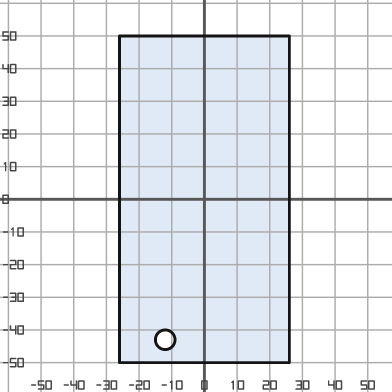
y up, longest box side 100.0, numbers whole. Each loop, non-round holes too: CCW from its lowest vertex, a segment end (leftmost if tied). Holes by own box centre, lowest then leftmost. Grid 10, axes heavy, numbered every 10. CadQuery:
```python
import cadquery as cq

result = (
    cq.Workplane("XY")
    .moveTo(-26.0, -50.0)
    .lineTo(26.0, -50.0)
    .lineTo(26.0, 50.0)
    .lineTo(-26.0, 50.0)
    .close()
    .moveTo(-12.0, -43.0)
    .circle(3.0)
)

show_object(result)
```